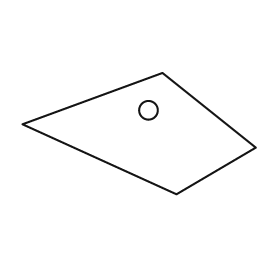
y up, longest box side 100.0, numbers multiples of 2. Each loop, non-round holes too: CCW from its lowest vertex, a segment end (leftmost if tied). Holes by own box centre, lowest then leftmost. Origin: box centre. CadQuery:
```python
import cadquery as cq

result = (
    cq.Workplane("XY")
    .moveTo(16.0, -26.0)
    .lineTo(50.0, -6.0)
    .lineTo(10.0, 26.0)
    .lineTo(-50.0, 4.0)
    .close()
    .moveTo(4.0, 10.0)
    .circle(4.0)
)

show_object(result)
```